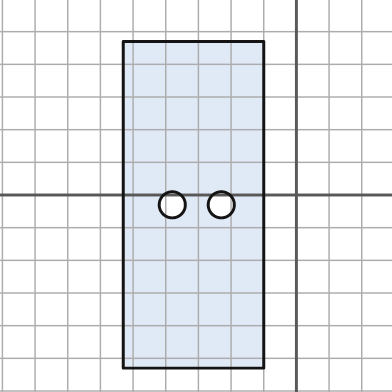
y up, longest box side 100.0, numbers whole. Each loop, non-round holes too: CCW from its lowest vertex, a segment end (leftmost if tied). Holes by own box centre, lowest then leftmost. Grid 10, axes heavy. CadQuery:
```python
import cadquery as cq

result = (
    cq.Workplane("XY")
    .moveTo(-53.0, -53.0)
    .lineTo(-10.0, -53.0)
    .lineTo(-10.0, 47.0)
    .lineTo(-53.0, 47.0)
    .close()
    .moveTo(-38.0, -3.0)
    .circle(4.0)
    .moveTo(-23.0, -3.0)
    .circle(4.0)
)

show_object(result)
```